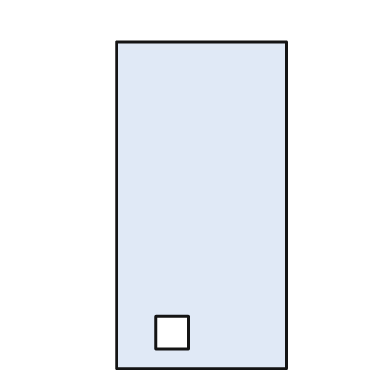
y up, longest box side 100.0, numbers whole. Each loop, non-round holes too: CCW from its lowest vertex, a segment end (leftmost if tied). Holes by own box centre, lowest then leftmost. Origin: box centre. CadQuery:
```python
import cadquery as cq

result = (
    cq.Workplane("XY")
    .moveTo(-26.0, -50.0)
    .lineTo(26.0, -50.0)
    .lineTo(26.0, 50.0)
    .lineTo(-26.0, 50.0)
    .close()
    .moveTo(-14.0, -44.0)
    .lineTo(-4.0, -44.0)
    .lineTo(-4.0, -34.0)
    .lineTo(-14.0, -34.0)
    .close()
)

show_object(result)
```